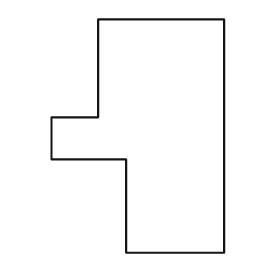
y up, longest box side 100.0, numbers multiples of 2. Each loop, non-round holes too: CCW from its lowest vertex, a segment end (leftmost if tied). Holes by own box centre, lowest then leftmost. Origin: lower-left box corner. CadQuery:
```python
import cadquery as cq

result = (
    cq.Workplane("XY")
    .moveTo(32.0, 0.0)
    .lineTo(74.0, 0.0)
    .lineTo(74.0, 100.0)
    .lineTo(20.0, 100.0)
    .lineTo(20.0, 58.0)
    .lineTo(0.0, 58.0)
    .lineTo(0.0, 40.0)
    .lineTo(32.0, 40.0)
    .close()
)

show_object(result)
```